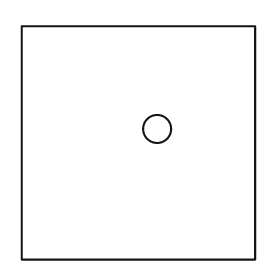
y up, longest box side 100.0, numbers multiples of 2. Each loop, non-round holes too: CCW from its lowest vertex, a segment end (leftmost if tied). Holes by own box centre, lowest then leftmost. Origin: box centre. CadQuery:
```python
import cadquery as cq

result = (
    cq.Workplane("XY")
    .moveTo(-50.0, -50.0)
    .lineTo(50.0, -50.0)
    .lineTo(50.0, 50.0)
    .lineTo(-50.0, 50.0)
    .close()
    .moveTo(8.0, 6.0)
    .circle(6.0)
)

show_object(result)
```